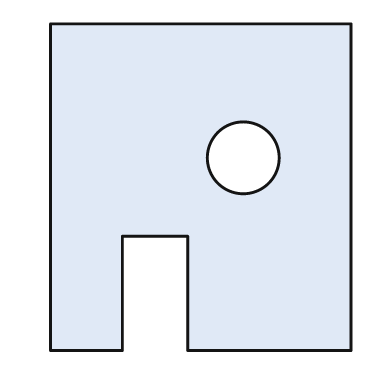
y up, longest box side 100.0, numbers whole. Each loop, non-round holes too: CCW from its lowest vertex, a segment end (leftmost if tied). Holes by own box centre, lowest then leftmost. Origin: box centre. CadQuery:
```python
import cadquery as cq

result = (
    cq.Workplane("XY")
    .moveTo(-46.0, -50.0)
    .lineTo(-24.0, -50.0)
    .lineTo(-24.0, -15.0)
    .lineTo(-4.0, -15.0)
    .lineTo(-4.0, -50.0)
    .lineTo(46.0, -50.0)
    .lineTo(46.0, 50.0)
    .lineTo(-46.0, 50.0)
    .close()
    .moveTo(13.0, 9.0)
    .circle(11.0)
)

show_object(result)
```